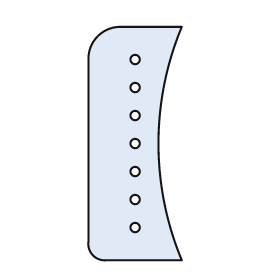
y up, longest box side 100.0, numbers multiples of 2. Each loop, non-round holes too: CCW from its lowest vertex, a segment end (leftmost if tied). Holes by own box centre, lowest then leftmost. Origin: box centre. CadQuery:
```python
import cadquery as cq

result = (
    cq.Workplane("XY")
    .moveTo(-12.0, -50.0)
    .lineTo(20.0, -50.0)
    .threePointArc((10.0, 0.0), (20.0, 50.0))
    .lineTo(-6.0, 50.0)
    .threePointArc((-16.0, 46.0), (-20.0, 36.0))
    .lineTo(-20.0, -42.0)
    .threePointArc((-18.0, -48.0), (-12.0, -50.0))
    .close()
    .moveTo(0.0, -36.0)
    .circle(2.0)
    .moveTo(0.0, -24.0)
    .circle(2.0)
    .moveTo(0.0, -12.0)
    .circle(2.0)
    .moveTo(0.0, 0.0)
    .circle(2.0)
    .moveTo(0.0, 12.0)
    .circle(2.0)
    .moveTo(0.0, 24.0)
    .circle(2.0)
    .moveTo(0.0, 36.0)
    .circle(2.0)
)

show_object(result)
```